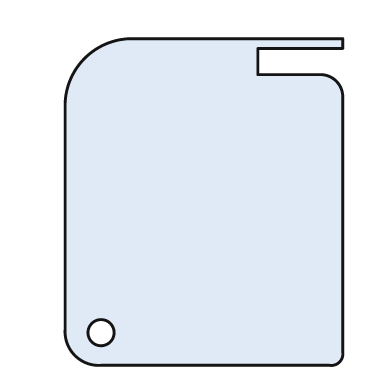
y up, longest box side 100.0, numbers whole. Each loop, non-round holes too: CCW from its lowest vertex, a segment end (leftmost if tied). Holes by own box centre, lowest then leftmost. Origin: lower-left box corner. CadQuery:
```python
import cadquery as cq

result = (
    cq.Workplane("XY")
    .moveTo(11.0, 0.0)
    .lineTo(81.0, 0.0)
    .threePointArc((84.0, 1.0), (85.0, 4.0))
    .lineTo(85.0, 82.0)
    .threePointArc((83.0, 87.0), (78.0, 89.0))
    .lineTo(59.0, 89.0)
    .lineTo(59.0, 97.0)
    .lineTo(85.0, 97.0)
    .lineTo(85.0, 100.0)
    .lineTo(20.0, 100.0)
    .threePointArc((6.0, 94.0), (0.0, 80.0))
    .lineTo(0.0, 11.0)
    .threePointArc((3.0, 3.0), (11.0, 0.0))
    .close()
    .moveTo(11.0, 10.0)
    .circle(4.0)
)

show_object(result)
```